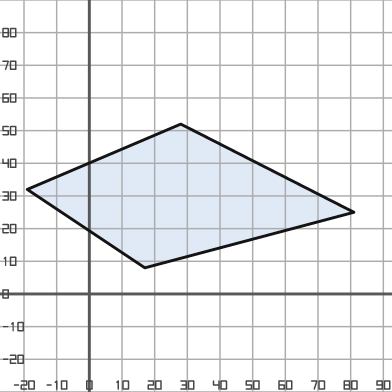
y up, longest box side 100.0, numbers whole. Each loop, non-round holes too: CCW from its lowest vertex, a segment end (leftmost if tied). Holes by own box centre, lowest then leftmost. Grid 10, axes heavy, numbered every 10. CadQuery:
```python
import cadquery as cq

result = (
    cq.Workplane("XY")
    .moveTo(17.0, 8.0)
    .lineTo(81.0, 25.0)
    .lineTo(28.0, 52.0)
    .lineTo(-19.0, 32.0)
    .close()
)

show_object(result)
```